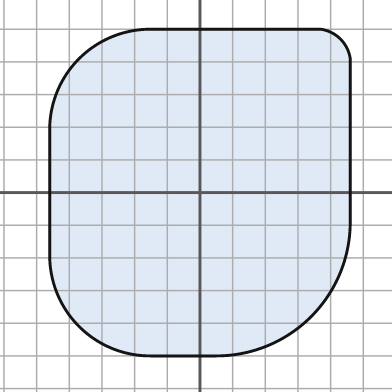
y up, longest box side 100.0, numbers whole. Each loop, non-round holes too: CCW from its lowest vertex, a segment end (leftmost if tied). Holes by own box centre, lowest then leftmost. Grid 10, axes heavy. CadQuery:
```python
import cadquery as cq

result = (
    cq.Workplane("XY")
    .moveTo(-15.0, -50.0)
    .lineTo(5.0, -50.0)
    .threePointArc((34.0, -38.0), (46.0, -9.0))
    .lineTo(46.0, 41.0)
    .threePointArc((43.0, 47.0), (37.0, 50.0))
    .lineTo(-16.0, 50.0)
    .threePointArc((-37.0, 41.0), (-46.0, 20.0))
    .lineTo(-46.0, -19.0)
    .threePointArc((-37.0, -41.0), (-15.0, -50.0))
    .close()
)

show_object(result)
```